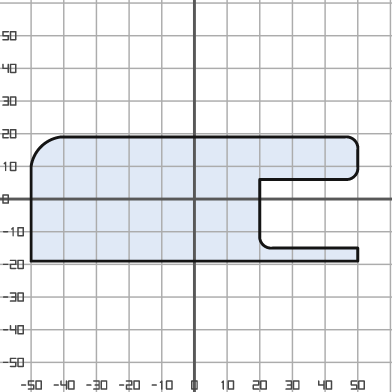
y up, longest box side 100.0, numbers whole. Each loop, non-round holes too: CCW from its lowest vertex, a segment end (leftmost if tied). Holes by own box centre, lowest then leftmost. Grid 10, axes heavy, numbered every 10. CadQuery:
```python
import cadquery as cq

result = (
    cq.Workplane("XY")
    .moveTo(-50.0, -19.0)
    .lineTo(50.0, -19.0)
    .lineTo(50.0, -15.0)
    .lineTo(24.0, -15.0)
    .threePointArc((21.0, -14.0), (20.0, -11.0))
    .lineTo(20.0, 6.0)
    .lineTo(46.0, 6.0)
    .threePointArc((49.0, 7.0), (50.0, 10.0))
    .lineTo(50.0, 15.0)
    .threePointArc((49.0, 18.0), (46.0, 19.0))
    .lineTo(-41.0, 19.0)
    .threePointArc((-47.0, 16.0), (-50.0, 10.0))
    .close()
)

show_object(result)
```